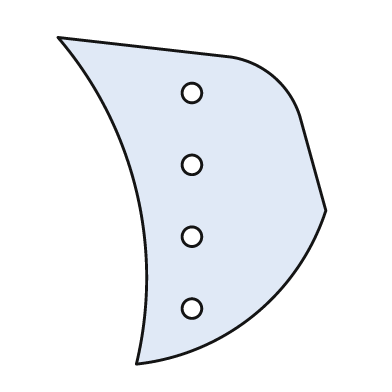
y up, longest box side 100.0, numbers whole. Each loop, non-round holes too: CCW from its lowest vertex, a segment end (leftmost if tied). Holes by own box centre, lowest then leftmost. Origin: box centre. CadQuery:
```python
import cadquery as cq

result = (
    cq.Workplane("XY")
    .moveTo(-17.0, -50.0)
    .threePointArc((19.0, -35.0), (41.0, -3.0))
    .lineTo(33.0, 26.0)
    .threePointArc((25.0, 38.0), (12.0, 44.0))
    .lineTo(-41.0, 50.0)
    .threePointArc((-17.0, 3.0), (-17.0, -50.0))
    .close()
    .moveTo(0.0, -33.0)
    .circle(3.0)
    .moveTo(0.0, -11.0)
    .circle(3.0)
    .moveTo(0.0, 11.0)
    .circle(3.0)
    .moveTo(0.0, 33.0)
    .circle(3.0)
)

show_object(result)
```